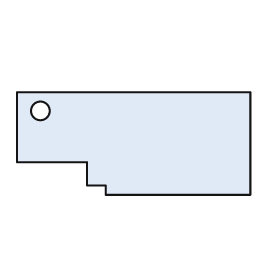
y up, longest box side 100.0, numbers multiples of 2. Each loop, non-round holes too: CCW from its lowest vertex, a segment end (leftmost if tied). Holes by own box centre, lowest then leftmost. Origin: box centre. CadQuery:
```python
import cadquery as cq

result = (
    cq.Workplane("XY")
    .moveTo(-12.0, -22.0)
    .lineTo(50.0, -22.0)
    .lineTo(50.0, 22.0)
    .lineTo(-50.0, 22.0)
    .lineTo(-50.0, -8.0)
    .lineTo(-20.0, -8.0)
    .lineTo(-20.0, -18.0)
    .lineTo(-12.0, -18.0)
    .close()
    .moveTo(-40.0, 14.0)
    .circle(4.0)
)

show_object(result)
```